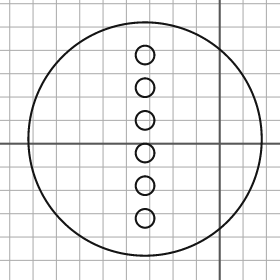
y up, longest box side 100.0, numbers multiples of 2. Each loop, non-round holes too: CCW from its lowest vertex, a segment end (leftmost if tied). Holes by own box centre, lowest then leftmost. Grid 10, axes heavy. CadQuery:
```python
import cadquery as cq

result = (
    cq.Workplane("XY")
    .moveTo(-32.0, 2.0)
    .circle(50.0)
    .moveTo(-32.0, -32.0)
    .circle(4.0)
    .moveTo(-32.0, -18.0)
    .circle(4.0)
    .moveTo(-32.0, -4.0)
    .circle(4.0)
    .moveTo(-32.0, 10.0)
    .circle(4.0)
    .moveTo(-32.0, 24.0)
    .circle(4.0)
    .moveTo(-32.0, 38.0)
    .circle(4.0)
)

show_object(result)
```